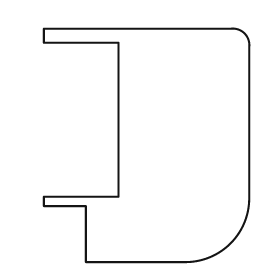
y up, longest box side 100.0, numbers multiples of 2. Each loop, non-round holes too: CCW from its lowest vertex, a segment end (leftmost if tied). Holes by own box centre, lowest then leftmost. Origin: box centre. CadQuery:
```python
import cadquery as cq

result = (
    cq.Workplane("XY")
    .moveTo(-26.0, -50.0)
    .lineTo(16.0, -50.0)
    .threePointArc((36.0, -42.0), (44.0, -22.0))
    .lineTo(44.0, 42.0)
    .threePointArc((42.0, 48.0), (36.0, 50.0))
    .lineTo(-44.0, 50.0)
    .lineTo(-44.0, 44.0)
    .lineTo(-12.0, 44.0)
    .lineTo(-12.0, -22.0)
    .lineTo(-44.0, -22.0)
    .lineTo(-44.0, -26.0)
    .lineTo(-26.0, -26.0)
    .close()
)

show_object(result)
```